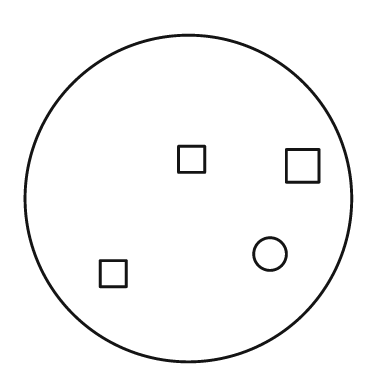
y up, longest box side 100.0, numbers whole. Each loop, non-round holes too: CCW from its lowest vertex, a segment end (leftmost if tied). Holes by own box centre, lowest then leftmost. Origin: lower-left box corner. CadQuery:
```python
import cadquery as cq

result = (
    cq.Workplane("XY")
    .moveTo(50.0, 50.0)
    .circle(50.0)
    .moveTo(23.0, 23.0)
    .lineTo(31.0, 23.0)
    .lineTo(31.0, 31.0)
    .lineTo(23.0, 31.0)
    .close()
    .moveTo(75.0, 33.0)
    .circle(5.0)
    .moveTo(80.0, 55.0)
    .lineTo(90.0, 55.0)
    .lineTo(90.0, 65.0)
    .lineTo(80.0, 65.0)
    .close()
    .moveTo(47.0, 58.0)
    .lineTo(55.0, 58.0)
    .lineTo(55.0, 66.0)
    .lineTo(47.0, 66.0)
    .close()
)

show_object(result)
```